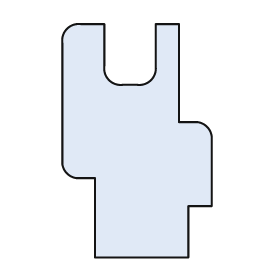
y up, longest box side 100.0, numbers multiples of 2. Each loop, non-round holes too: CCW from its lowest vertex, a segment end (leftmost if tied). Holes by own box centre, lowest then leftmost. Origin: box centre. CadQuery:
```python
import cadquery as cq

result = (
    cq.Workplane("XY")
    .moveTo(-18.0, -50.0)
    .lineTo(22.0, -50.0)
    .lineTo(22.0, -28.0)
    .lineTo(32.0, -28.0)
    .lineTo(32.0, 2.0)
    .threePointArc((30.0, 6.0), (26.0, 8.0))
    .lineTo(18.0, 8.0)
    .lineTo(18.0, 50.0)
    .lineTo(8.0, 50.0)
    .lineTo(8.0, 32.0)
    .threePointArc((6.0, 26.0), (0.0, 24.0))
    .lineTo(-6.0, 24.0)
    .threePointArc((-12.0, 26.0), (-14.0, 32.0))
    .lineTo(-14.0, 50.0)
    .lineTo(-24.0, 50.0)
    .threePointArc((-30.0, 48.0), (-32.0, 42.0))
    .lineTo(-32.0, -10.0)
    .threePointArc((-30.0, -14.0), (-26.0, -16.0))
    .lineTo(-18.0, -16.0)
    .close()
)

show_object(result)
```